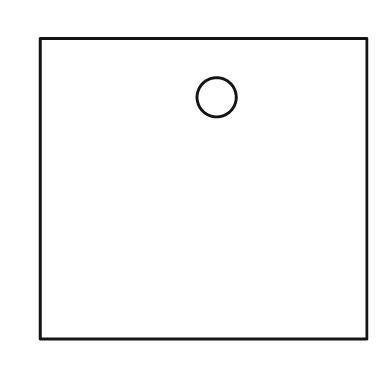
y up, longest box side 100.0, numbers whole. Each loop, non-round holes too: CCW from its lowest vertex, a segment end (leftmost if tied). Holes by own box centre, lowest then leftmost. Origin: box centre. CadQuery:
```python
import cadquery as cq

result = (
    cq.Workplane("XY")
    .moveTo(-50.0, -46.0)
    .lineTo(50.0, -46.0)
    .lineTo(50.0, 46.0)
    .lineTo(-50.0, 46.0)
    .close()
    .moveTo(4.0, 28.0)
    .circle(6.0)
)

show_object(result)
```